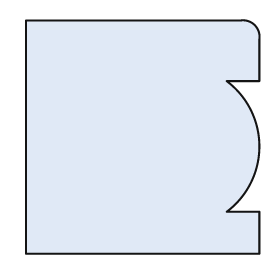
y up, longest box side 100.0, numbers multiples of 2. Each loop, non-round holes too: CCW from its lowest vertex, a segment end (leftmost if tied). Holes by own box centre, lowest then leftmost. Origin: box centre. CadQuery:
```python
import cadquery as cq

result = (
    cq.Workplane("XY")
    .moveTo(-50.0, -50.0)
    .lineTo(50.0, -50.0)
    .lineTo(50.0, -32.0)
    .lineTo(36.0, -32.0)
    .threePointArc((50.0, -4.0), (36.0, 24.0))
    .lineTo(50.0, 24.0)
    .lineTo(50.0, 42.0)
    .threePointArc((48.0, 48.0), (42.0, 50.0))
    .lineTo(-50.0, 50.0)
    .close()
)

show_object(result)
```